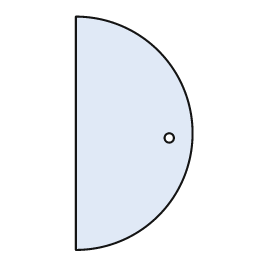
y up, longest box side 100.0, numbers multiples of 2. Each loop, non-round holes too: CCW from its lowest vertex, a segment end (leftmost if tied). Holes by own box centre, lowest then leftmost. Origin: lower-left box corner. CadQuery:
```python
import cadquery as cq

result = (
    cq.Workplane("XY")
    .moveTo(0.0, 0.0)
    .threePointArc((50.0, 50.0), (0.0, 100.0))
    .close()
    .moveTo(40.0, 48.0)
    .circle(2.0)
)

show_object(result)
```